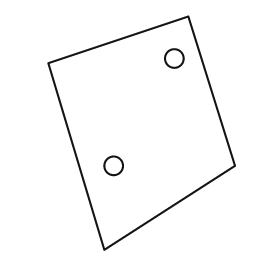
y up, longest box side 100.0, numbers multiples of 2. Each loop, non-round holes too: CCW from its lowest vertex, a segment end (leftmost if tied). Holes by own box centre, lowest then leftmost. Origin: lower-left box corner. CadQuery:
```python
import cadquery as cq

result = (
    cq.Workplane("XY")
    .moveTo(24.0, 0.0)
    .lineTo(80.0, 36.0)
    .lineTo(60.0, 100.0)
    .lineTo(0.0, 80.0)
    .close()
    .moveTo(28.0, 36.0)
    .circle(4.0)
    .moveTo(54.0, 82.0)
    .circle(4.0)
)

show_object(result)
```